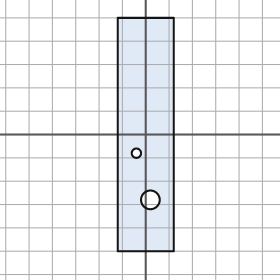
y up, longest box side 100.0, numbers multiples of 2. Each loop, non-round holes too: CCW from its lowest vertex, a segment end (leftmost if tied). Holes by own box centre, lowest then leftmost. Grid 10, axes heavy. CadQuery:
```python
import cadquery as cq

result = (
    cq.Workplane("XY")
    .moveTo(-12.0, -50.0)
    .lineTo(12.0, -50.0)
    .lineTo(12.0, 50.0)
    .lineTo(-12.0, 50.0)
    .close()
    .moveTo(2.0, -28.0)
    .circle(4.0)
    .moveTo(-4.0, -8.0)
    .circle(2.0)
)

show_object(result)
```